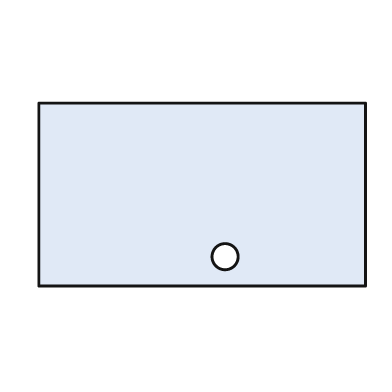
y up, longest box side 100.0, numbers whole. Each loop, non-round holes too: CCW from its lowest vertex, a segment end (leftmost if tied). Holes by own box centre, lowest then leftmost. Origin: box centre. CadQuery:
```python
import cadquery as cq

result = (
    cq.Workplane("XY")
    .moveTo(-50.0, -28.0)
    .lineTo(50.0, -28.0)
    .lineTo(50.0, 28.0)
    .lineTo(-50.0, 28.0)
    .close()
    .moveTo(7.0, -19.0)
    .circle(4.0)
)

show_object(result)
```